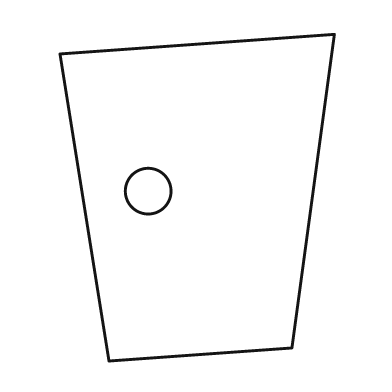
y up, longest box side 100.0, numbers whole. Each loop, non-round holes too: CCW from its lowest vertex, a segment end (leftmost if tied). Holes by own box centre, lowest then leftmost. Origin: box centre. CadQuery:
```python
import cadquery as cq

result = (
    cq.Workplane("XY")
    .moveTo(-27.0, -50.0)
    .lineTo(29.0, -46.0)
    .lineTo(42.0, 50.0)
    .lineTo(-42.0, 44.0)
    .close()
    .moveTo(-15.0, 2.0)
    .circle(7.0)
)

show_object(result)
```